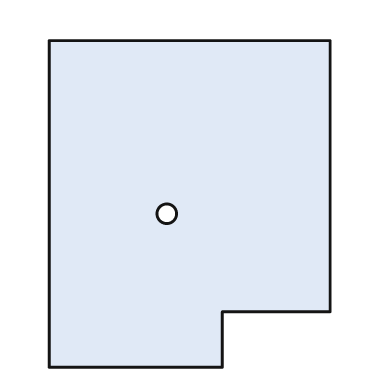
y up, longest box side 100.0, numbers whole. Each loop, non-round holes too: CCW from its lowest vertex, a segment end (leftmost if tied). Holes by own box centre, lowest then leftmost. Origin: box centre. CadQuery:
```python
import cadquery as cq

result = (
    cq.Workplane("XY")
    .moveTo(-43.0, -50.0)
    .lineTo(10.0, -50.0)
    .lineTo(10.0, -33.0)
    .lineTo(43.0, -33.0)
    .lineTo(43.0, 50.0)
    .lineTo(-43.0, 50.0)
    .close()
    .moveTo(-7.0, -3.0)
    .circle(3.0)
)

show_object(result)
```